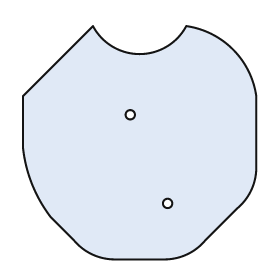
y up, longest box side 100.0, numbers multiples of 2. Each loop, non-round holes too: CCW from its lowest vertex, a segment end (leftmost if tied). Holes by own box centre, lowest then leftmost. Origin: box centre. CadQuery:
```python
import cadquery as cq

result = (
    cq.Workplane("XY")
    .moveTo(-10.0, -50.0)
    .lineTo(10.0, -50.0)
    .threePointArc((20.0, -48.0), (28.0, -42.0))
    .lineTo(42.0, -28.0)
    .threePointArc((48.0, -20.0), (50.0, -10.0))
    .lineTo(50.0, 20.0)
    .threePointArc((40.0, 40.0), (20.0, 50.0))
    .threePointArc((0.0, 38.0), (-20.0, 50.0))
    .lineTo(-50.0, 20.0)
    .lineTo(-50.0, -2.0)
    .threePointArc((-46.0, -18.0), (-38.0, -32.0))
    .lineTo(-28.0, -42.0)
    .threePointArc((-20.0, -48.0), (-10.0, -50.0))
    .close()
    .moveTo(12.0, -26.0)
    .circle(2.0)
    .moveTo(-4.0, 12.0)
    .circle(2.0)
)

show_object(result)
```